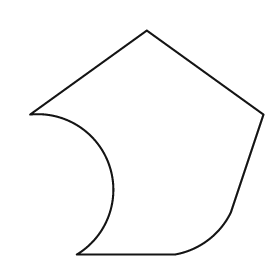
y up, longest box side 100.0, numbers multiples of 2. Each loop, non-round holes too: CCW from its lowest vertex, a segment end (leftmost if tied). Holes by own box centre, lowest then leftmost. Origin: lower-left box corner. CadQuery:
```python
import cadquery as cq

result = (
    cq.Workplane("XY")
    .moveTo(20.0, 0.0)
    .lineTo(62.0, 0.0)
    .threePointArc((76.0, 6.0), (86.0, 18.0))
    .lineTo(100.0, 60.0)
    .lineTo(50.0, 96.0)
    .lineTo(0.0, 60.0)
    .threePointArc((34.0, 38.0), (20.0, 0.0))
    .close()
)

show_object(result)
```